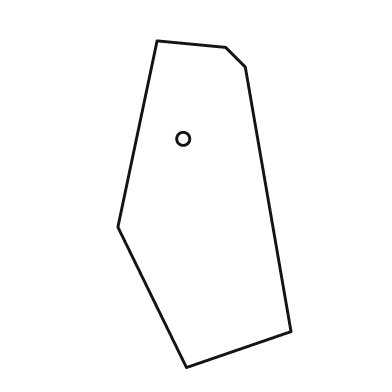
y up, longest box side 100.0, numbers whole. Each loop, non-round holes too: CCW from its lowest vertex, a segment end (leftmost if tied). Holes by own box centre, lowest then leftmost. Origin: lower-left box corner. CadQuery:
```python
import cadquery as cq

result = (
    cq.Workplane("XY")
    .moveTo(21.0, 0.0)
    .lineTo(53.0, 11.0)
    .lineTo(39.0, 92.0)
    .lineTo(33.0, 98.0)
    .lineTo(12.0, 100.0)
    .lineTo(0.0, 43.0)
    .close()
    .moveTo(20.0, 70.0)
    .circle(2.0)
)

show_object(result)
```